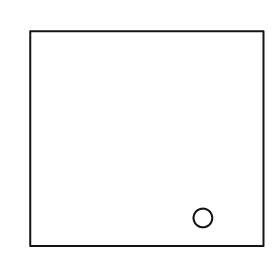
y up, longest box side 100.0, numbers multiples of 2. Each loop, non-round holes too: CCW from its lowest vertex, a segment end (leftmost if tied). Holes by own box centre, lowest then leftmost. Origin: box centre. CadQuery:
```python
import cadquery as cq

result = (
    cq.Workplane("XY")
    .moveTo(-50.0, -46.0)
    .lineTo(50.0, -46.0)
    .lineTo(50.0, 46.0)
    .lineTo(-50.0, 46.0)
    .close()
    .moveTo(24.0, -34.0)
    .circle(4.0)
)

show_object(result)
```